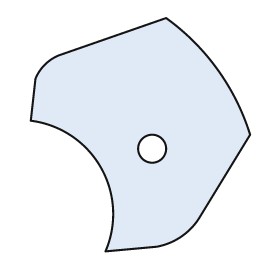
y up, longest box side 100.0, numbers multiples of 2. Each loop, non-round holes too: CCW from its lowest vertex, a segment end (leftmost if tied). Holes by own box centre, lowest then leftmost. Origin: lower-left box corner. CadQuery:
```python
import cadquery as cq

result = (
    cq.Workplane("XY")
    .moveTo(32.0, 0.0)
    .lineTo(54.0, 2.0)
    .threePointArc((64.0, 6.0), (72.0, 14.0))
    .lineTo(94.0, 50.0)
    .threePointArc((80.0, 78.0), (58.0, 100.0))
    .lineTo(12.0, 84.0)
    .threePointArc((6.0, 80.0), (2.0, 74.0))
    .lineTo(0.0, 56.0)
    .threePointArc((30.0, 36.0), (32.0, 0.0))
    .close()
    .moveTo(52.0, 44.0)
    .circle(6.0)
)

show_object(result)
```